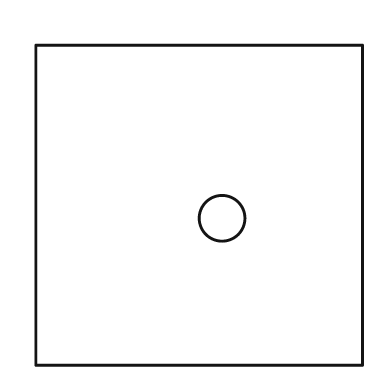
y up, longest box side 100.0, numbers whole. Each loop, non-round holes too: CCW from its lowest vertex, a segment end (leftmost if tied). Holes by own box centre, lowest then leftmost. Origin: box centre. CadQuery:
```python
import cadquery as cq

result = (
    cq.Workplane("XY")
    .moveTo(-50.0, -49.0)
    .lineTo(50.0, -49.0)
    .lineTo(50.0, 49.0)
    .lineTo(-50.0, 49.0)
    .close()
    .moveTo(7.0, -4.0)
    .circle(7.0)
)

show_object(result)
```